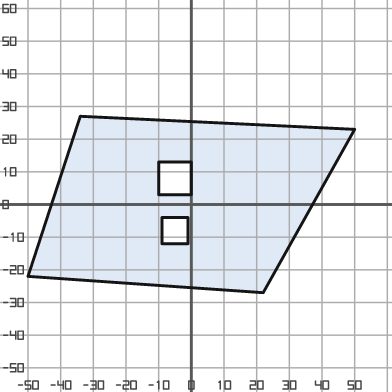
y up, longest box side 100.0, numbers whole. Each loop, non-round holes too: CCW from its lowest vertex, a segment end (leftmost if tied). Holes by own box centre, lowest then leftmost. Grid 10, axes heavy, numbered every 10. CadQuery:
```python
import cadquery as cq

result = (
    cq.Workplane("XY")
    .moveTo(22.0, -27.0)
    .lineTo(50.0, 23.0)
    .lineTo(-34.0, 27.0)
    .lineTo(-50.0, -22.0)
    .close()
    .moveTo(-9.0, -12.0)
    .lineTo(-1.0, -12.0)
    .lineTo(-1.0, -4.0)
    .lineTo(-9.0, -4.0)
    .close()
    .moveTo(-10.0, 3.0)
    .lineTo(0.0, 3.0)
    .lineTo(0.0, 13.0)
    .lineTo(-10.0, 13.0)
    .close()
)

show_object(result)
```